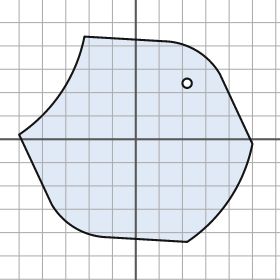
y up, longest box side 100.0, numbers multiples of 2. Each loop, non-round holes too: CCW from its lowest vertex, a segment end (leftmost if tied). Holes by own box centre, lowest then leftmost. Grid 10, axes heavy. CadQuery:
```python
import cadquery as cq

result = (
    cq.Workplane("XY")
    .moveTo(22.0, -44.0)
    .threePointArc((40.0, -26.0), (50.0, -2.0))
    .lineTo(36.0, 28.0)
    .threePointArc((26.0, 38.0), (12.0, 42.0))
    .lineTo(-22.0, 44.0)
    .threePointArc((-32.0, 20.0), (-50.0, 2.0))
    .lineTo(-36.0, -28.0)
    .threePointArc((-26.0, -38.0), (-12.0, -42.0))
    .close()
    .moveTo(22.0, 24.0)
    .circle(2.0)
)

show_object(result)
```